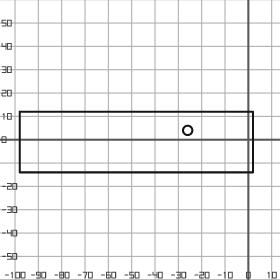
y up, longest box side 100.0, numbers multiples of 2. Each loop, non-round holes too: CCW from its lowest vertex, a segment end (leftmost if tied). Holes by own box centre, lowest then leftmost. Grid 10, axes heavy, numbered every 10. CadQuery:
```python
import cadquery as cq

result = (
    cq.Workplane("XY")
    .moveTo(-98.0, -14.0)
    .lineTo(2.0, -14.0)
    .lineTo(2.0, 12.0)
    .lineTo(-98.0, 12.0)
    .close()
    .moveTo(-26.0, 4.0)
    .circle(2.0)
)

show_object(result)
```